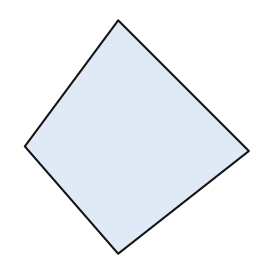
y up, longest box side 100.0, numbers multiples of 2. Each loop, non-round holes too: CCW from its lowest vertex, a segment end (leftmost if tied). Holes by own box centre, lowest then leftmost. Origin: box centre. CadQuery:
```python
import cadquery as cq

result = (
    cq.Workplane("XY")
    .moveTo(-8.0, -50.0)
    .lineTo(48.0, -6.0)
    .lineTo(-8.0, 50.0)
    .lineTo(-48.0, -4.0)
    .close()
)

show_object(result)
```